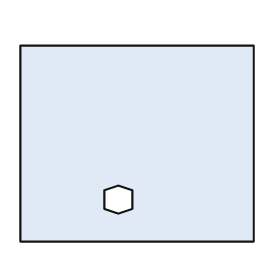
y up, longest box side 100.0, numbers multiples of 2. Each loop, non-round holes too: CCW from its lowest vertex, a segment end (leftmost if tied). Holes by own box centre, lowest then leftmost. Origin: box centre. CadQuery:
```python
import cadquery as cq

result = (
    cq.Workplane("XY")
    .moveTo(-50.0, -42.0)
    .lineTo(50.0, -42.0)
    .lineTo(50.0, 42.0)
    .lineTo(-50.0, 42.0)
    .close()
    .moveTo(-8.0, -30.0)
    .lineTo(-2.0, -28.0)
    .lineTo(-2.0, -20.0)
    .lineTo(-8.0, -18.0)
    .lineTo(-14.0, -20.0)
    .lineTo(-14.0, -28.0)
    .close()
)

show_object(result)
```